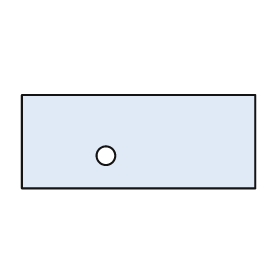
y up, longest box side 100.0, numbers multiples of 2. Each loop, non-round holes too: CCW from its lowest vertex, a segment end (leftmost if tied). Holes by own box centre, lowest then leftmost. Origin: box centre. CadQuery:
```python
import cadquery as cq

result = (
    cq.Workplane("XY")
    .moveTo(-50.0, -20.0)
    .lineTo(50.0, -20.0)
    .lineTo(50.0, 20.0)
    .lineTo(-50.0, 20.0)
    .close()
    .moveTo(-14.0, -6.0)
    .circle(4.0)
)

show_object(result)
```